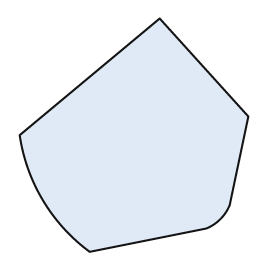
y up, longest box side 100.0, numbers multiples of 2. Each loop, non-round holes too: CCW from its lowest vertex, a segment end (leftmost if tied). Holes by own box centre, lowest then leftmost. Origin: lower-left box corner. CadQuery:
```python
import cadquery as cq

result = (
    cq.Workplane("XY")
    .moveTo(30.0, 0.0)
    .lineTo(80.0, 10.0)
    .threePointArc((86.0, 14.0), (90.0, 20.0))
    .lineTo(98.0, 58.0)
    .lineTo(60.0, 100.0)
    .lineTo(0.0, 50.0)
    .threePointArc((10.0, 22.0), (30.0, 0.0))
    .close()
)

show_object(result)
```